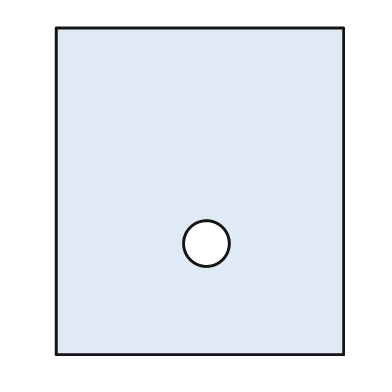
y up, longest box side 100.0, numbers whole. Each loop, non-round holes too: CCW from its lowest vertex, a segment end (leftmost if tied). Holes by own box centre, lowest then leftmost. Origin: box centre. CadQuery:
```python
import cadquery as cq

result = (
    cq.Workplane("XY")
    .moveTo(-44.0, -50.0)
    .lineTo(44.0, -50.0)
    .lineTo(44.0, 50.0)
    .lineTo(-44.0, 50.0)
    .close()
    .moveTo(2.0, -16.0)
    .circle(7.0)
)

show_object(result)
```